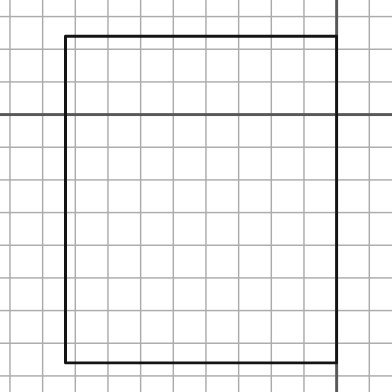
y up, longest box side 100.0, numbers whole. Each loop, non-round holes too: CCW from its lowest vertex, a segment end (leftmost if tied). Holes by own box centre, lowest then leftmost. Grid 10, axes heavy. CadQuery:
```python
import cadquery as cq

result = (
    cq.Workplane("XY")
    .moveTo(-83.0, -76.0)
    .lineTo(0.0, -76.0)
    .lineTo(0.0, 24.0)
    .lineTo(-83.0, 24.0)
    .close()
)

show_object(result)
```